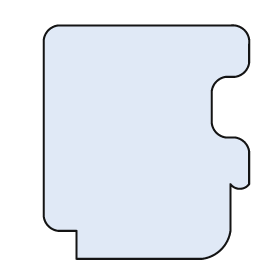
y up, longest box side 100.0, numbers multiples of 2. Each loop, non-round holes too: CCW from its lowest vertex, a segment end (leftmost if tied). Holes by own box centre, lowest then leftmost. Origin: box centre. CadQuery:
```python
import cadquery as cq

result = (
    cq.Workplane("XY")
    .moveTo(-30.0, -50.0)
    .lineTo(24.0, -50.0)
    .threePointArc((32.0, -46.0), (36.0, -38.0))
    .lineTo(36.0, -18.0)
    .threePointArc((40.0, -20.0), (44.0, -18.0))
    .lineTo(44.0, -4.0)
    .threePointArc((42.0, 0.0), (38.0, 2.0))
    .lineTo(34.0, 2.0)
    .threePointArc((30.0, 4.0), (28.0, 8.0))
    .lineTo(28.0, 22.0)
    .threePointArc((30.0, 26.0), (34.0, 28.0))
    .lineTo(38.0, 28.0)
    .threePointArc((42.0, 30.0), (44.0, 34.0))
    .lineTo(44.0, 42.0)
    .threePointArc((42.0, 48.0), (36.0, 50.0))
    .lineTo(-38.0, 50.0)
    .threePointArc((-42.0, 48.0), (-44.0, 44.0))
    .lineTo(-44.0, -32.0)
    .threePointArc((-42.0, -36.0), (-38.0, -38.0))
    .lineTo(-30.0, -38.0)
    .close()
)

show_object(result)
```